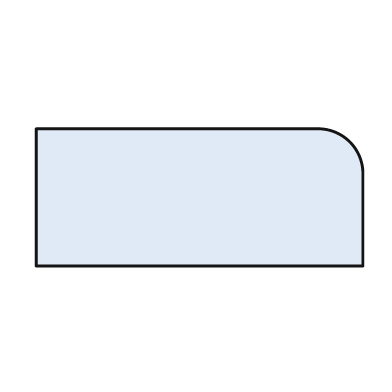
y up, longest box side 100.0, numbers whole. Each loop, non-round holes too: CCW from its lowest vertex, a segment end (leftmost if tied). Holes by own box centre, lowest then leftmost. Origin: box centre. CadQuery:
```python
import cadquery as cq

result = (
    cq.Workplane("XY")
    .moveTo(-50.0, -21.0)
    .lineTo(50.0, -21.0)
    .lineTo(50.0, 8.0)
    .threePointArc((46.0, 17.0), (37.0, 21.0))
    .lineTo(-50.0, 21.0)
    .close()
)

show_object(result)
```